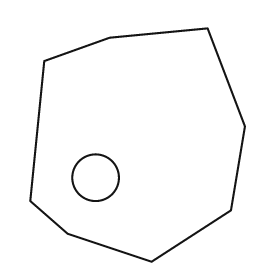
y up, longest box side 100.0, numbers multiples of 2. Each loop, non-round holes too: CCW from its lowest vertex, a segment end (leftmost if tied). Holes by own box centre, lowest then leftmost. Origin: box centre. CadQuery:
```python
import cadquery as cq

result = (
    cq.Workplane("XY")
    .moveTo(6.0, -50.0)
    .lineTo(40.0, -28.0)
    .lineTo(46.0, 8.0)
    .lineTo(30.0, 50.0)
    .lineTo(-12.0, 46.0)
    .lineTo(-40.0, 36.0)
    .lineTo(-46.0, -24.0)
    .lineTo(-30.0, -38.0)
    .close()
    .moveTo(-18.0, -14.0)
    .circle(10.0)
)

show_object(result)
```